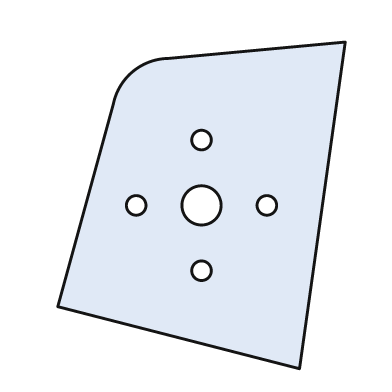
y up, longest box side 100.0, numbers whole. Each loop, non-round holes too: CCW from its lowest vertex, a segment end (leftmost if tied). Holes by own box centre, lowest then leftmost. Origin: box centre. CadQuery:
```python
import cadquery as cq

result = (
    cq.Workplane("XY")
    .moveTo(30.0, -50.0)
    .lineTo(44.0, 50.0)
    .lineTo(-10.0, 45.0)
    .threePointArc((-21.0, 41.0), (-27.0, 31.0))
    .lineTo(-44.0, -31.0)
    .close()
    .moveTo(0.0, -20.0)
    .circle(3.0)
    .moveTo(-20.0, 0.0)
    .circle(3.0)
    .moveTo(0.0, 0.0)
    .circle(6.0)
    .moveTo(20.0, 0.0)
    .circle(3.0)
    .moveTo(0.0, 20.0)
    .circle(3.0)
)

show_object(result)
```